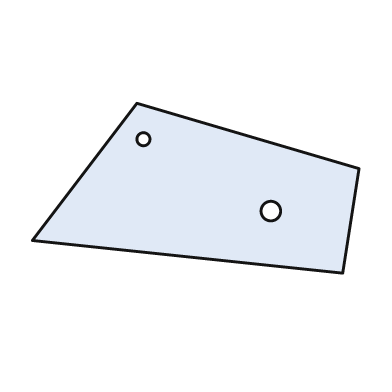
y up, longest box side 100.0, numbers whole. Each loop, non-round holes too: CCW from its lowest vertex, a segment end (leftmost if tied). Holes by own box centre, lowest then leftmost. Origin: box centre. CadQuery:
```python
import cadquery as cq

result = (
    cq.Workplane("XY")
    .moveTo(45.0, -26.0)
    .lineTo(50.0, 6.0)
    .lineTo(-18.0, 26.0)
    .lineTo(-50.0, -16.0)
    .close()
    .moveTo(23.0, -7.0)
    .circle(3.0)
    .moveTo(-16.0, 15.0)
    .circle(2.0)
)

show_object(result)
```